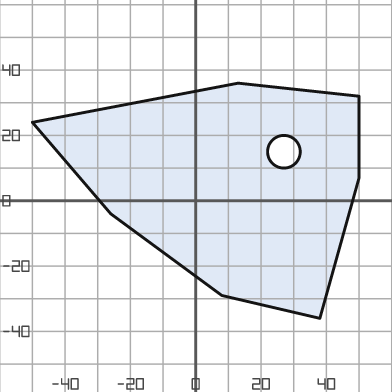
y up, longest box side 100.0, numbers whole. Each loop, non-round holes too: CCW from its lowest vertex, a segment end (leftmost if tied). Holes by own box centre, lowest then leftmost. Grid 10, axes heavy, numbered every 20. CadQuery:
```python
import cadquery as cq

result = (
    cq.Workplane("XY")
    .moveTo(38.0, -36.0)
    .lineTo(50.0, 7.0)
    .lineTo(50.0, 32.0)
    .lineTo(13.0, 36.0)
    .lineTo(-50.0, 24.0)
    .lineTo(-26.0, -4.0)
    .lineTo(8.0, -29.0)
    .close()
    .moveTo(27.0, 15.0)
    .circle(5.0)
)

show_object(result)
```